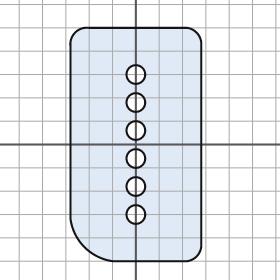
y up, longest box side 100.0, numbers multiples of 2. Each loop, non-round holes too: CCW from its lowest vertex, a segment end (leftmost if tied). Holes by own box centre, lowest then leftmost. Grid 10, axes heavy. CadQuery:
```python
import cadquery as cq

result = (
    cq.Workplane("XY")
    .moveTo(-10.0, -50.0)
    .lineTo(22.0, -50.0)
    .threePointArc((26.0, -48.0), (28.0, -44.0))
    .lineTo(28.0, 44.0)
    .threePointArc((26.0, 48.0), (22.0, 50.0))
    .lineTo(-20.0, 50.0)
    .threePointArc((-26.0, 48.0), (-28.0, 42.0))
    .lineTo(-28.0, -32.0)
    .threePointArc((-22.0, -44.0), (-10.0, -50.0))
    .close()
    .moveTo(0.0, -30.0)
    .circle(4.0)
    .moveTo(0.0, -18.0)
    .circle(4.0)
    .moveTo(0.0, -6.0)
    .circle(4.0)
    .moveTo(0.0, 6.0)
    .circle(4.0)
    .moveTo(0.0, 18.0)
    .circle(4.0)
    .moveTo(0.0, 30.0)
    .circle(4.0)
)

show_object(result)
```